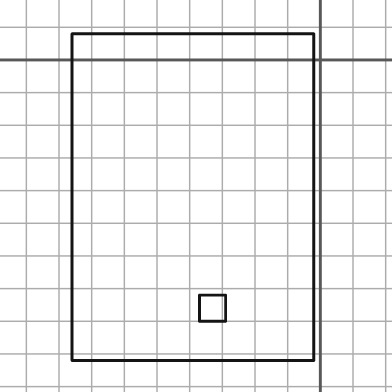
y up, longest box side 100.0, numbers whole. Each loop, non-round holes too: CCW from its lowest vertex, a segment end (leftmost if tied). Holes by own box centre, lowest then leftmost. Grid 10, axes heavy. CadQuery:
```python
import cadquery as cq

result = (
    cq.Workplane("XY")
    .moveTo(-76.0, -92.0)
    .lineTo(-2.0, -92.0)
    .lineTo(-2.0, 8.0)
    .lineTo(-76.0, 8.0)
    .close()
    .moveTo(-37.0, -80.0)
    .lineTo(-29.0, -80.0)
    .lineTo(-29.0, -72.0)
    .lineTo(-37.0, -72.0)
    .close()
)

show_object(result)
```